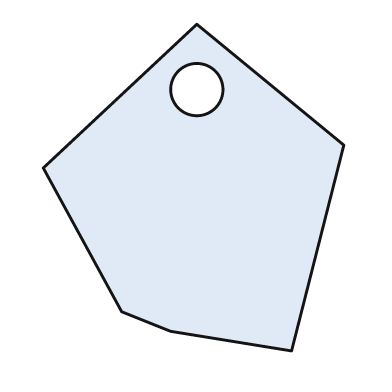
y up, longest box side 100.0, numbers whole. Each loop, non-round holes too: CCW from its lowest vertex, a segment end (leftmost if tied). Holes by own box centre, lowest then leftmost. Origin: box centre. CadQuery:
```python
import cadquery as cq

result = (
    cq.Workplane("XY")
    .moveTo(30.0, -50.0)
    .lineTo(46.0, 13.0)
    .lineTo(1.0, 50.0)
    .lineTo(-46.0, 6.0)
    .lineTo(-22.0, -38.0)
    .lineTo(-7.0, -44.0)
    .close()
    .moveTo(1.0, 30.0)
    .circle(8.0)
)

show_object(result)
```